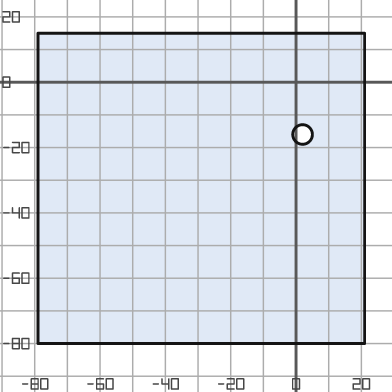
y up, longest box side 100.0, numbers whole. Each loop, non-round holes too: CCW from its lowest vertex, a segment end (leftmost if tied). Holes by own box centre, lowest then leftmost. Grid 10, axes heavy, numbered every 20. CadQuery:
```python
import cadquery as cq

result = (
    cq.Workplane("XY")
    .moveTo(-79.0, -80.0)
    .lineTo(21.0, -80.0)
    .lineTo(21.0, 15.0)
    .lineTo(-79.0, 15.0)
    .close()
    .moveTo(2.0, -16.0)
    .circle(3.0)
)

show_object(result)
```